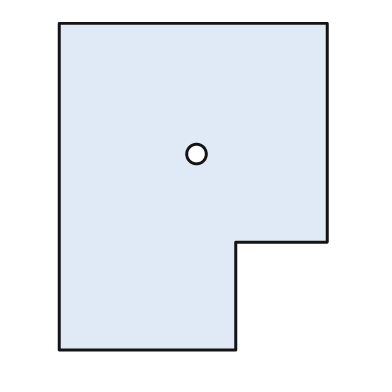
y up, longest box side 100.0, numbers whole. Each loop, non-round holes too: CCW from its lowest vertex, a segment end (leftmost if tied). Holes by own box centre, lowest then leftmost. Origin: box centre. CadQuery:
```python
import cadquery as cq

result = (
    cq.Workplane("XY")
    .moveTo(-41.0, -50.0)
    .lineTo(13.0, -50.0)
    .lineTo(13.0, -17.0)
    .lineTo(41.0, -17.0)
    .lineTo(41.0, 50.0)
    .lineTo(-41.0, 50.0)
    .close()
    .moveTo(1.0, 10.0)
    .circle(3.0)
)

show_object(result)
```